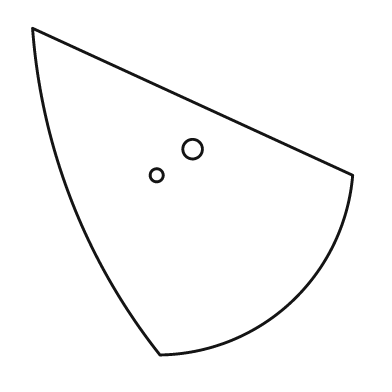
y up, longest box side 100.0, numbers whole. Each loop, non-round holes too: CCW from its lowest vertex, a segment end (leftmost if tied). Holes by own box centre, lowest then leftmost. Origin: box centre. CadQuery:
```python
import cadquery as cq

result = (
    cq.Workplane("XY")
    .moveTo(-10.0, -50.0)
    .threePointArc((30.0, -34.0), (49.0, 5.0))
    .lineTo(-49.0, 50.0)
    .threePointArc((-37.0, -3.0), (-10.0, -50.0))
    .close()
    .moveTo(-11.0, 5.0)
    .circle(2.0)
    .moveTo(0.0, 13.0)
    .circle(3.0)
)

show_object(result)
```